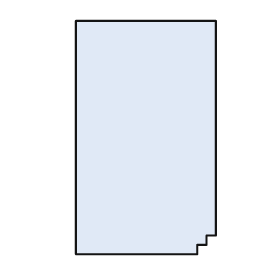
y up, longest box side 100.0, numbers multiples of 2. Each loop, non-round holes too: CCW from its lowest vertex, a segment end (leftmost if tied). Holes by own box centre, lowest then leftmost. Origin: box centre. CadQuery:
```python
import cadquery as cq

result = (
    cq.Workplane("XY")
    .moveTo(-30.0, -50.0)
    .lineTo(22.0, -50.0)
    .lineTo(22.0, -46.0)
    .lineTo(26.0, -46.0)
    .lineTo(26.0, -42.0)
    .lineTo(30.0, -42.0)
    .lineTo(30.0, 50.0)
    .lineTo(-30.0, 50.0)
    .close()
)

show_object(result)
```